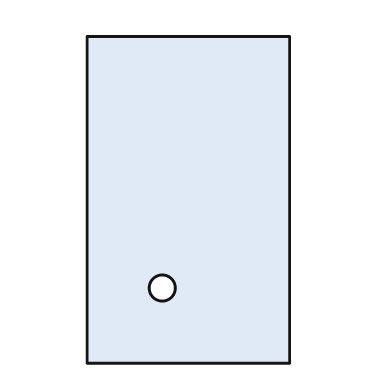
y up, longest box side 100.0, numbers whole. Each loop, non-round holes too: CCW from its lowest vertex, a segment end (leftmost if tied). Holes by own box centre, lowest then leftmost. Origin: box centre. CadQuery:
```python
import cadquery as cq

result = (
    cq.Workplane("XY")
    .moveTo(-31.0, -50.0)
    .lineTo(31.0, -50.0)
    .lineTo(31.0, 50.0)
    .lineTo(-31.0, 50.0)
    .close()
    .moveTo(-8.0, -27.0)
    .circle(4.0)
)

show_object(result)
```